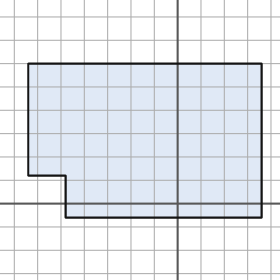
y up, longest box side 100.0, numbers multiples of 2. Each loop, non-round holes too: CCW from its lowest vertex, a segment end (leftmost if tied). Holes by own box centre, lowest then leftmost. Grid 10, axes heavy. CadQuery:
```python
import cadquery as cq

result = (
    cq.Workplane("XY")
    .moveTo(-48.0, -6.0)
    .lineTo(36.0, -6.0)
    .lineTo(36.0, 60.0)
    .lineTo(-64.0, 60.0)
    .lineTo(-64.0, 12.0)
    .lineTo(-48.0, 12.0)
    .close()
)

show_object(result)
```